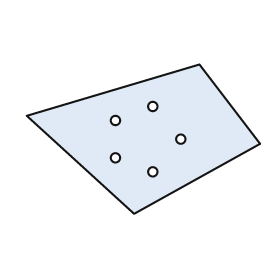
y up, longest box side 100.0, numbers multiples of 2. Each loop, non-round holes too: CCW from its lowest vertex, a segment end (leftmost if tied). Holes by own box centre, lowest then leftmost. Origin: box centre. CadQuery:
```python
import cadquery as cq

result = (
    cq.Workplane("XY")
    .moveTo(-4.0, -32.0)
    .lineTo(50.0, -2.0)
    .lineTo(24.0, 32.0)
    .lineTo(-50.0, 10.0)
    .close()
    .moveTo(4.0, -14.0)
    .circle(2.0)
    .moveTo(-12.0, -8.0)
    .circle(2.0)
    .moveTo(16.0, 0.0)
    .circle(2.0)
    .moveTo(-12.0, 8.0)
    .circle(2.0)
    .moveTo(4.0, 14.0)
    .circle(2.0)
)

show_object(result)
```